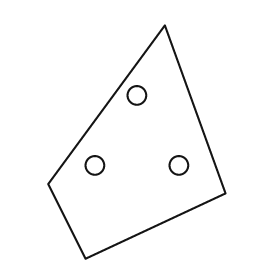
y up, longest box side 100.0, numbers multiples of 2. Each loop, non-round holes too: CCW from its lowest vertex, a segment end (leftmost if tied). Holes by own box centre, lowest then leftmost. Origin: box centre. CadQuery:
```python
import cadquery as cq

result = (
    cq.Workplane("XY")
    .moveTo(-22.0, -50.0)
    .lineTo(38.0, -22.0)
    .lineTo(12.0, 50.0)
    .lineTo(-38.0, -18.0)
    .close()
    .moveTo(-18.0, -10.0)
    .circle(4.0)
    .moveTo(18.0, -10.0)
    .circle(4.0)
    .moveTo(0.0, 20.0)
    .circle(4.0)
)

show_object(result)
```